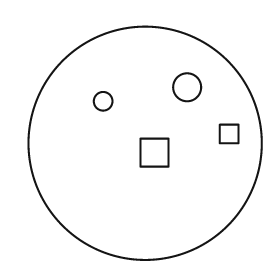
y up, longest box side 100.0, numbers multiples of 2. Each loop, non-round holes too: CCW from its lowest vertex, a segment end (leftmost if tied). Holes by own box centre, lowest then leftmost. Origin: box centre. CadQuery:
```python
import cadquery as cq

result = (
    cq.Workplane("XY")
    .moveTo(0.0, 0.0)
    .circle(50.0)
    .moveTo(-2.0, -10.0)
    .lineTo(10.0, -10.0)
    .lineTo(10.0, 2.0)
    .lineTo(-2.0, 2.0)
    .close()
    .moveTo(32.0, 0.0)
    .lineTo(40.0, 0.0)
    .lineTo(40.0, 8.0)
    .lineTo(32.0, 8.0)
    .close()
    .moveTo(-18.0, 18.0)
    .circle(4.0)
    .moveTo(18.0, 24.0)
    .circle(6.0)
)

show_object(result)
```